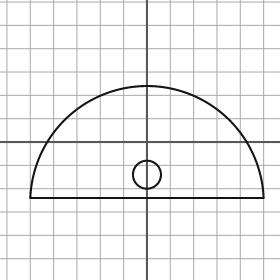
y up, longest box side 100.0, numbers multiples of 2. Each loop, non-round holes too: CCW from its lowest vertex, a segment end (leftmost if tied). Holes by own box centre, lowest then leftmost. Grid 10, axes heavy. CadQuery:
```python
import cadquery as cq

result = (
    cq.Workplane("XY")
    .moveTo(-50.0, -24.0)
    .lineTo(50.0, -24.0)
    .threePointArc((0.0, 24.0), (-50.0, -24.0))
    .close()
    .moveTo(0.0, -14.0)
    .circle(6.0)
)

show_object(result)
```